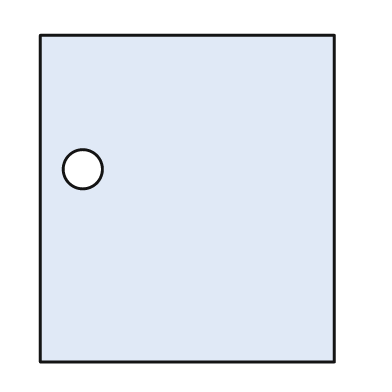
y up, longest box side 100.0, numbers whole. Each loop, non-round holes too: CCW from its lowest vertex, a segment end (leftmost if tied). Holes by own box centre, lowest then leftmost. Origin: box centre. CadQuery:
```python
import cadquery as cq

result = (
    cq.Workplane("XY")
    .moveTo(-45.0, -50.0)
    .lineTo(45.0, -50.0)
    .lineTo(45.0, 50.0)
    .lineTo(-45.0, 50.0)
    .close()
    .moveTo(-32.0, 9.0)
    .circle(6.0)
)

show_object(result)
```